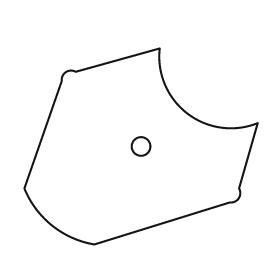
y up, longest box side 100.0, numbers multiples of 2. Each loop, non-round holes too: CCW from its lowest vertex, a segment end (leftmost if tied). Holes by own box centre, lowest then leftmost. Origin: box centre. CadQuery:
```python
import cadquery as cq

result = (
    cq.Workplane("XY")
    .moveTo(-20.0, -42.0)
    .lineTo(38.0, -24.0)
    .threePointArc((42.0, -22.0), (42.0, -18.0))
    .lineTo(50.0, 10.0)
    .threePointArc((20.0, 14.0), (8.0, 42.0))
    .lineTo(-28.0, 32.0)
    .threePointArc((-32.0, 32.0), (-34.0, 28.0))
    .lineTo(-50.0, -18.0)
    .threePointArc((-38.0, -34.0), (-20.0, -42.0))
    .close()
    .moveTo(0.0, 0.0)
    .circle(4.0)
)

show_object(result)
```